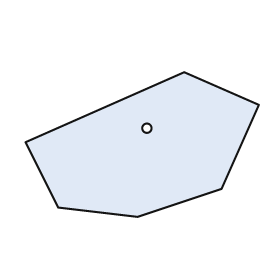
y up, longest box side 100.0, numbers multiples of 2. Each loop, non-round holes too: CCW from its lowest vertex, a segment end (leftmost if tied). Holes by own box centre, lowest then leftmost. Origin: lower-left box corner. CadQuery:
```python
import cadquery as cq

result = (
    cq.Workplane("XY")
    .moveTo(48.0, 0.0)
    .lineTo(84.0, 12.0)
    .lineTo(100.0, 48.0)
    .lineTo(68.0, 62.0)
    .lineTo(0.0, 32.0)
    .lineTo(14.0, 4.0)
    .close()
    .moveTo(52.0, 38.0)
    .circle(2.0)
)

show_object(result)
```